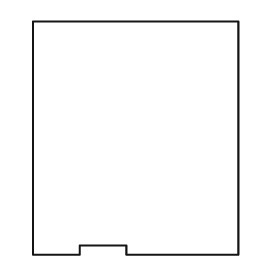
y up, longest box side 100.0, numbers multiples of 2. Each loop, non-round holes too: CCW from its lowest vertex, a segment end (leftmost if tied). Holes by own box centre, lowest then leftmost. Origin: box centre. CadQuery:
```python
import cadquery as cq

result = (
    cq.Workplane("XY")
    .moveTo(-44.0, -50.0)
    .lineTo(-24.0, -50.0)
    .lineTo(-24.0, -46.0)
    .lineTo(-4.0, -46.0)
    .lineTo(-4.0, -50.0)
    .lineTo(44.0, -50.0)
    .lineTo(44.0, 50.0)
    .lineTo(-44.0, 50.0)
    .close()
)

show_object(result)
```